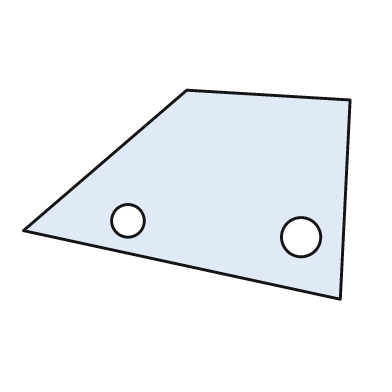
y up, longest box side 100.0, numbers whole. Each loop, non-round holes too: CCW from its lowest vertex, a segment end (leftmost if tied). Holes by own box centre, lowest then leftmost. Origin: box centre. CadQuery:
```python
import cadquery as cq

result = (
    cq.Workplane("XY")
    .moveTo(47.0, -32.0)
    .lineTo(50.0, 29.0)
    .lineTo(0.0, 32.0)
    .lineTo(-50.0, -11.0)
    .close()
    .moveTo(35.0, -13.0)
    .circle(6.0)
    .moveTo(-18.0, -8.0)
    .circle(5.0)
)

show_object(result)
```